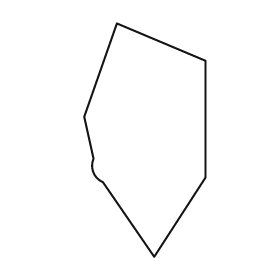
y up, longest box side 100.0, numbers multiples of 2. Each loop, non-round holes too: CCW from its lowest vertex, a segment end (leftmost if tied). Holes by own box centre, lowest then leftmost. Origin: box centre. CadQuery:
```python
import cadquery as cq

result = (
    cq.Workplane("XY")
    .moveTo(4.0, -50.0)
    .lineTo(26.0, -16.0)
    .lineTo(26.0, 34.0)
    .lineTo(-12.0, 50.0)
    .lineTo(-26.0, 10.0)
    .lineTo(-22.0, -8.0)
    .threePointArc((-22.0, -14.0), (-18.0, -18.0))
    .close()
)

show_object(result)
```